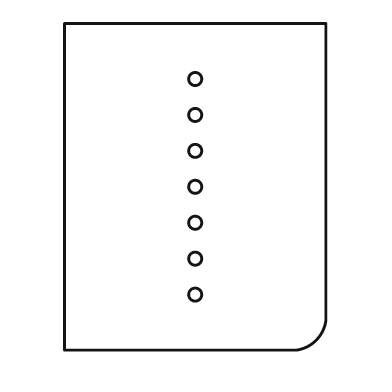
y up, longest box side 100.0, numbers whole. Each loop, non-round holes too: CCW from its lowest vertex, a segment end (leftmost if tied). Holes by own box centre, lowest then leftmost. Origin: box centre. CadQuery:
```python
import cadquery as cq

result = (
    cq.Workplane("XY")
    .moveTo(-40.0, -50.0)
    .lineTo(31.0, -50.0)
    .threePointArc((37.0, -47.0), (40.0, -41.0))
    .lineTo(40.0, 50.0)
    .lineTo(-40.0, 50.0)
    .close()
    .moveTo(0.0, -33.0)
    .circle(2.0)
    .moveTo(0.0, -22.0)
    .circle(2.0)
    .moveTo(0.0, -11.0)
    .circle(2.0)
    .moveTo(0.0, 0.0)
    .circle(2.0)
    .moveTo(0.0, 11.0)
    .circle(2.0)
    .moveTo(0.0, 22.0)
    .circle(2.0)
    .moveTo(0.0, 33.0)
    .circle(2.0)
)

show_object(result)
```